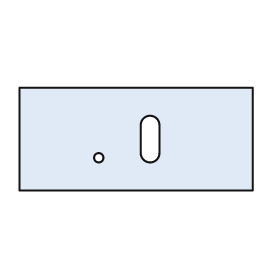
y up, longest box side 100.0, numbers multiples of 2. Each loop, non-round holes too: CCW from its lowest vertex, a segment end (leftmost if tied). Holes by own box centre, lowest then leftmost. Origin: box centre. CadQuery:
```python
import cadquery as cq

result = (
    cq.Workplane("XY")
    .moveTo(-50.0, -22.0)
    .lineTo(50.0, -22.0)
    .lineTo(50.0, 22.0)
    .lineTo(-50.0, 22.0)
    .close()
    .moveTo(-16.0, -8.0)
    .circle(2.0)
    .moveTo(2.0, -6.0)
    .threePointArc((6.0, -10.0), (10.0, -6.0))
    .lineTo(10.0, 6.0)
    .threePointArc((6.0, 10.0), (2.0, 6.0))
    .close()
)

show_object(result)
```